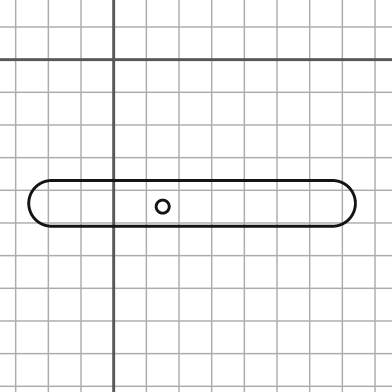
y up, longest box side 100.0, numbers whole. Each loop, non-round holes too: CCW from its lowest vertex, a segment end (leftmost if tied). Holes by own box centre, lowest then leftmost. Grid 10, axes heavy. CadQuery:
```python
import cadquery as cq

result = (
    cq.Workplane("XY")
    .moveTo(-19.0, -51.0)
    .lineTo(67.0, -51.0)
    .threePointArc((74.0, -44.0), (67.0, -37.0))
    .lineTo(-19.0, -37.0)
    .threePointArc((-26.0, -44.0), (-19.0, -51.0))
    .close()
    .moveTo(15.0, -45.0)
    .circle(2.0)
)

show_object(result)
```